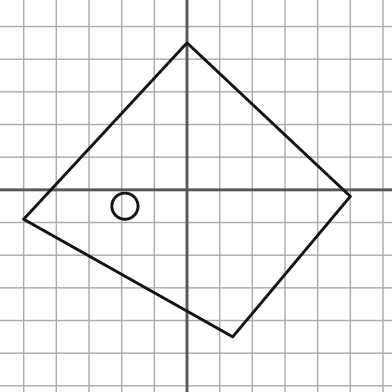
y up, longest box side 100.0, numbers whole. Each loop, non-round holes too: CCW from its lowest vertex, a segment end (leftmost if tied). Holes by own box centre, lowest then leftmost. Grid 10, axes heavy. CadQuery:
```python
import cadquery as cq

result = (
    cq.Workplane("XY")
    .moveTo(14.0, -45.0)
    .lineTo(50.0, -2.0)
    .lineTo(0.0, 45.0)
    .lineTo(-50.0, -9.0)
    .close()
    .moveTo(-19.0, -5.0)
    .circle(4.0)
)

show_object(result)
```